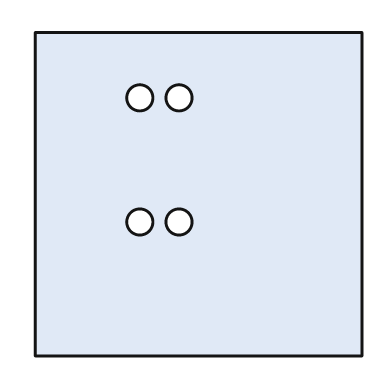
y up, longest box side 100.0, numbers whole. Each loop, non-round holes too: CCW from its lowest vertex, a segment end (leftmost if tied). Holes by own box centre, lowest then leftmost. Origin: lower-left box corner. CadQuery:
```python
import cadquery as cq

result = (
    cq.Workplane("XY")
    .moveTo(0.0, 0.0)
    .lineTo(100.0, 0.0)
    .lineTo(100.0, 99.0)
    .lineTo(0.0, 99.0)
    .close()
    .moveTo(32.0, 41.0)
    .circle(4.0)
    .moveTo(44.0, 41.0)
    .circle(4.0)
    .moveTo(32.0, 79.0)
    .circle(4.0)
    .moveTo(44.0, 79.0)
    .circle(4.0)
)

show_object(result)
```